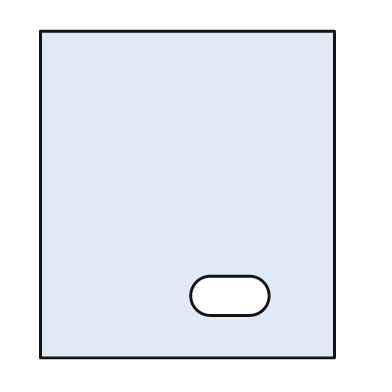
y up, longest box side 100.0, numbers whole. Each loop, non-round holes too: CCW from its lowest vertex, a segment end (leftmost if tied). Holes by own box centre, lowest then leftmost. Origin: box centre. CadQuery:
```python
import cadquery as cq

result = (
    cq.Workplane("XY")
    .moveTo(-45.0, -50.0)
    .lineTo(45.0, -50.0)
    .lineTo(45.0, 50.0)
    .lineTo(-45.0, 50.0)
    .close()
    .moveTo(7.0, -37.0)
    .lineTo(19.0, -37.0)
    .threePointArc((25.0, -31.0), (19.0, -25.0))
    .lineTo(7.0, -25.0)
    .threePointArc((1.0, -31.0), (7.0, -37.0))
    .close()
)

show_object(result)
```